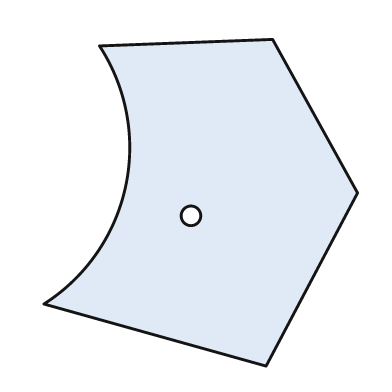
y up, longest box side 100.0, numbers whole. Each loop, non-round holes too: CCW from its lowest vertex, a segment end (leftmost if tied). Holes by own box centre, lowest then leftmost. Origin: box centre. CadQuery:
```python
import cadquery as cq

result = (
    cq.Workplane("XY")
    .moveTo(20.0, -50.0)
    .lineTo(48.0, 3.0)
    .lineTo(22.0, 50.0)
    .lineTo(-31.0, 48.0)
    .threePointArc((-23.0, 5.0), (-48.0, -31.0))
    .close()
    .moveTo(-3.0, -4.0)
    .circle(3.0)
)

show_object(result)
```